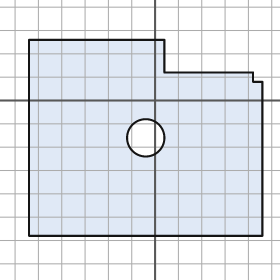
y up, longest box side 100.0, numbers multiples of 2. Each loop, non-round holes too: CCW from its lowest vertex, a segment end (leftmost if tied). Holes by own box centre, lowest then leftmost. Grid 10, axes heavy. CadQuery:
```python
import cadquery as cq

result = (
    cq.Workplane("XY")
    .moveTo(-54.0, -58.0)
    .lineTo(46.0, -58.0)
    .lineTo(46.0, 8.0)
    .lineTo(42.0, 8.0)
    .lineTo(42.0, 12.0)
    .lineTo(4.0, 12.0)
    .lineTo(4.0, 26.0)
    .lineTo(-54.0, 26.0)
    .close()
    .moveTo(-4.0, -16.0)
    .circle(8.0)
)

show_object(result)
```